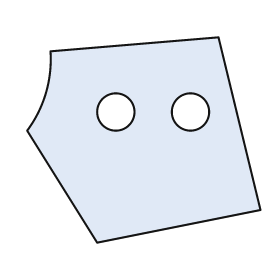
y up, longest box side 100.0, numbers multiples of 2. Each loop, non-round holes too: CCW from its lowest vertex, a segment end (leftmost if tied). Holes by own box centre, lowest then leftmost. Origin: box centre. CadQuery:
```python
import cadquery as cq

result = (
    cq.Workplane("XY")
    .moveTo(-20.0, -44.0)
    .lineTo(50.0, -30.0)
    .lineTo(32.0, 44.0)
    .lineTo(-40.0, 38.0)
    .threePointArc((-42.0, 20.0), (-50.0, 4.0))
    .close()
    .moveTo(-12.0, 12.0)
    .circle(8.0)
    .moveTo(20.0, 12.0)
    .circle(8.0)
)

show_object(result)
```